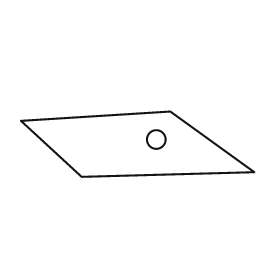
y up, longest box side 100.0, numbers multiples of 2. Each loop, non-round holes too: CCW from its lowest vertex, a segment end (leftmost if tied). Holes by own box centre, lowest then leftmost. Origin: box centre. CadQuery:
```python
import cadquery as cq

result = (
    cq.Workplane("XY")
    .moveTo(-24.0, -14.0)
    .lineTo(50.0, -12.0)
    .lineTo(14.0, 14.0)
    .lineTo(-50.0, 10.0)
    .close()
    .moveTo(8.0, 2.0)
    .circle(4.0)
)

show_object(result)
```